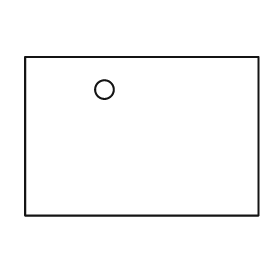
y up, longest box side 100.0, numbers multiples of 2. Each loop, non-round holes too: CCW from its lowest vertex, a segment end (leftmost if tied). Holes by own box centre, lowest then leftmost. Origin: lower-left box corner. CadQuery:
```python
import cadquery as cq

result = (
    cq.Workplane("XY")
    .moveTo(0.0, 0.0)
    .lineTo(100.0, 0.0)
    .lineTo(100.0, 68.0)
    .lineTo(0.0, 68.0)
    .close()
    .moveTo(34.0, 54.0)
    .circle(4.0)
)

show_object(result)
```